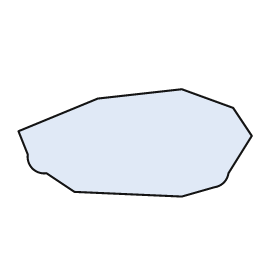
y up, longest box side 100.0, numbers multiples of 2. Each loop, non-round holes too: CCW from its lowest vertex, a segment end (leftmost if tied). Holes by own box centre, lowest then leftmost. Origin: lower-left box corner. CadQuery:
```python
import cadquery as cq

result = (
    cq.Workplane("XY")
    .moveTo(70.0, 0.0)
    .lineTo(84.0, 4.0)
    .threePointArc((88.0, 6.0), (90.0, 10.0))
    .lineTo(100.0, 26.0)
    .lineTo(92.0, 38.0)
    .lineTo(70.0, 46.0)
    .lineTo(34.0, 42.0)
    .lineTo(0.0, 28.0)
    .lineTo(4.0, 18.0)
    .threePointArc((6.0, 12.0), (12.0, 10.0))
    .lineTo(24.0, 2.0)
    .close()
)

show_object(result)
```